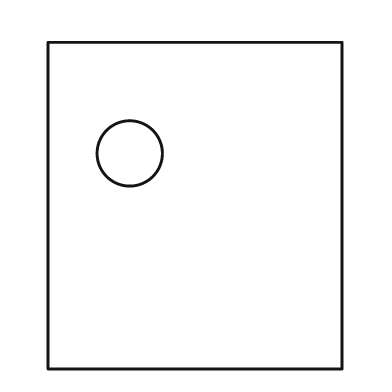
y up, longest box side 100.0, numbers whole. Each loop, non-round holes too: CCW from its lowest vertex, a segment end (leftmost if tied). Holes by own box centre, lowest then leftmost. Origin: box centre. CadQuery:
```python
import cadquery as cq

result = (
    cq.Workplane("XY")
    .moveTo(-45.0, -50.0)
    .lineTo(45.0, -50.0)
    .lineTo(45.0, 50.0)
    .lineTo(-45.0, 50.0)
    .close()
    .moveTo(-20.0, 16.0)
    .circle(10.0)
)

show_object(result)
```